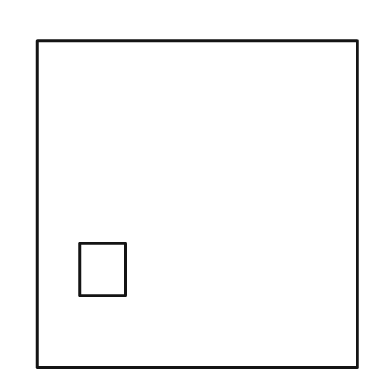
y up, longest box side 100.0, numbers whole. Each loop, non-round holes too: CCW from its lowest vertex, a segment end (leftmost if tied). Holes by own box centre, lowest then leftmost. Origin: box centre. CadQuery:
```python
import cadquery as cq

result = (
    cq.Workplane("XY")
    .moveTo(-49.0, -50.0)
    .lineTo(49.0, -50.0)
    .lineTo(49.0, 50.0)
    .lineTo(-49.0, 50.0)
    .close()
    .moveTo(-36.0, -28.0)
    .lineTo(-22.0, -28.0)
    .lineTo(-22.0, -12.0)
    .lineTo(-36.0, -12.0)
    .close()
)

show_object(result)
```